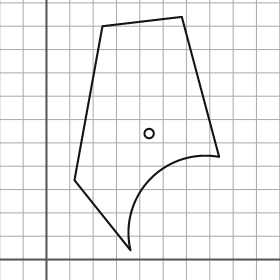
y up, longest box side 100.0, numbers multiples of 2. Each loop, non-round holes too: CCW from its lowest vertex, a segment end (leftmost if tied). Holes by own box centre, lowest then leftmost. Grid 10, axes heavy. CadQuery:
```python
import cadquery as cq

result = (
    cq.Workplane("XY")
    .moveTo(36.0, 4.0)
    .threePointArc((44.0, 34.0), (74.0, 44.0))
    .lineTo(58.0, 104.0)
    .lineTo(24.0, 100.0)
    .lineTo(12.0, 34.0)
    .close()
    .moveTo(44.0, 54.0)
    .circle(2.0)
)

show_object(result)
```